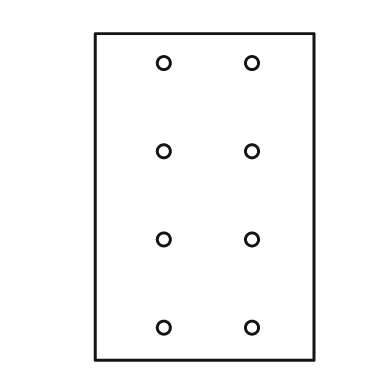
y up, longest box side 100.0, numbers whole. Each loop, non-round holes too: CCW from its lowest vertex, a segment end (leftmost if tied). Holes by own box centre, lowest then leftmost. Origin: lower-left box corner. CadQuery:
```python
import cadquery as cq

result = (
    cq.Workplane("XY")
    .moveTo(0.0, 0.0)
    .lineTo(67.0, 0.0)
    .lineTo(67.0, 100.0)
    .lineTo(0.0, 100.0)
    .close()
    .moveTo(21.0, 10.0)
    .circle(2.0)
    .moveTo(48.0, 10.0)
    .circle(2.0)
    .moveTo(21.0, 37.0)
    .circle(2.0)
    .moveTo(48.0, 37.0)
    .circle(2.0)
    .moveTo(21.0, 64.0)
    .circle(2.0)
    .moveTo(48.0, 64.0)
    .circle(2.0)
    .moveTo(21.0, 91.0)
    .circle(2.0)
    .moveTo(48.0, 91.0)
    .circle(2.0)
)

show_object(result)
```